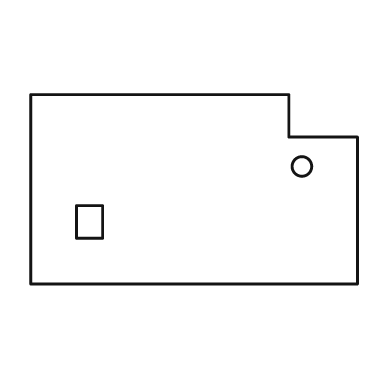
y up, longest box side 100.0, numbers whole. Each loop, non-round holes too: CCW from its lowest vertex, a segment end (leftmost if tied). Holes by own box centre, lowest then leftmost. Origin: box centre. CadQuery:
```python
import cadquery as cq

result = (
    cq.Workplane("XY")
    .moveTo(-50.0, -29.0)
    .lineTo(50.0, -29.0)
    .lineTo(50.0, 16.0)
    .lineTo(29.0, 16.0)
    .lineTo(29.0, 29.0)
    .lineTo(-50.0, 29.0)
    .close()
    .moveTo(-36.0, -15.0)
    .lineTo(-28.0, -15.0)
    .lineTo(-28.0, -5.0)
    .lineTo(-36.0, -5.0)
    .close()
    .moveTo(33.0, 7.0)
    .circle(3.0)
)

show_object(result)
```